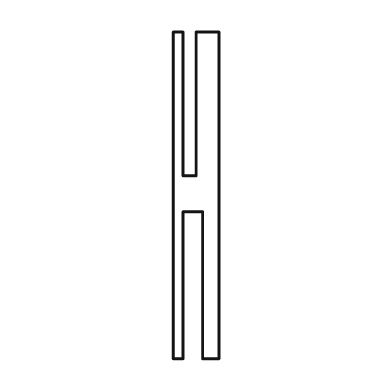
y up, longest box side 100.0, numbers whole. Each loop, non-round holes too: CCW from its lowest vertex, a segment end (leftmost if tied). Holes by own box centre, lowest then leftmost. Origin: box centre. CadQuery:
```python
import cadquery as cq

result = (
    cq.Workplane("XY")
    .moveTo(-7.0, -50.0)
    .lineTo(-4.0, -50.0)
    .lineTo(-4.0, -5.0)
    .lineTo(2.0, -5.0)
    .lineTo(2.0, -50.0)
    .lineTo(7.0, -50.0)
    .lineTo(7.0, 50.0)
    .lineTo(0.0, 50.0)
    .lineTo(0.0, 6.0)
    .lineTo(-4.0, 6.0)
    .lineTo(-4.0, 50.0)
    .lineTo(-7.0, 50.0)
    .close()
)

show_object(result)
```